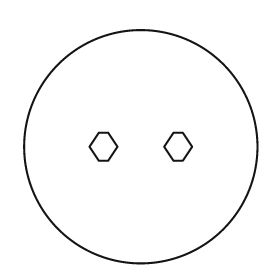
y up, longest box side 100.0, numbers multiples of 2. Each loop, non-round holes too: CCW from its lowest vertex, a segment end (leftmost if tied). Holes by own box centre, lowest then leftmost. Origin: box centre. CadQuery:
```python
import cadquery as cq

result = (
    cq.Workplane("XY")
    .moveTo(0.0, 0.0)
    .circle(50.0)
    .moveTo(-18.0, -6.0)
    .lineTo(-14.0, -6.0)
    .lineTo(-10.0, 0.0)
    .lineTo(-14.0, 6.0)
    .lineTo(-18.0, 6.0)
    .lineTo(-22.0, 0.0)
    .close()
    .moveTo(14.0, -6.0)
    .lineTo(18.0, -6.0)
    .lineTo(22.0, 0.0)
    .lineTo(18.0, 6.0)
    .lineTo(14.0, 6.0)
    .lineTo(10.0, 0.0)
    .close()
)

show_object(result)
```